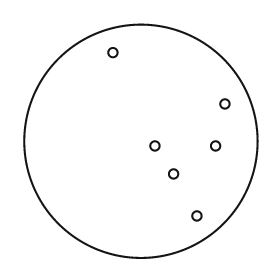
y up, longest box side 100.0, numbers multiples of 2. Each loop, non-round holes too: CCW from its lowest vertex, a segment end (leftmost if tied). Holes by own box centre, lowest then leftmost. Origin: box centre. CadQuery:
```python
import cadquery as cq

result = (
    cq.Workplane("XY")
    .moveTo(0.0, 0.0)
    .circle(50.0)
    .moveTo(24.0, -32.0)
    .circle(2.0)
    .moveTo(14.0, -14.0)
    .circle(2.0)
    .moveTo(6.0, -2.0)
    .circle(2.0)
    .moveTo(32.0, -2.0)
    .circle(2.0)
    .moveTo(36.0, 16.0)
    .circle(2.0)
    .moveTo(-12.0, 38.0)
    .circle(2.0)
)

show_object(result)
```